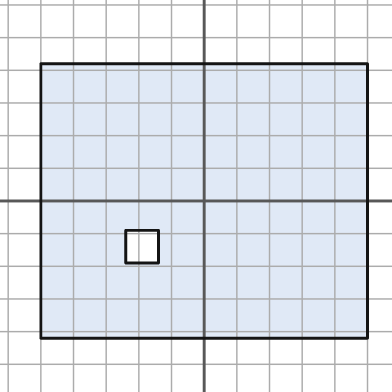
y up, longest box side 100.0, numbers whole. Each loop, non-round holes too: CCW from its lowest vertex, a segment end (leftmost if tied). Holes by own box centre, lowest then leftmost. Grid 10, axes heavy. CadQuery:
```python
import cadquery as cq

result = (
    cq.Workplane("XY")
    .moveTo(-50.0, -42.0)
    .lineTo(50.0, -42.0)
    .lineTo(50.0, 42.0)
    .lineTo(-50.0, 42.0)
    .close()
    .moveTo(-24.0, -19.0)
    .lineTo(-14.0, -19.0)
    .lineTo(-14.0, -9.0)
    .lineTo(-24.0, -9.0)
    .close()
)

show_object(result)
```